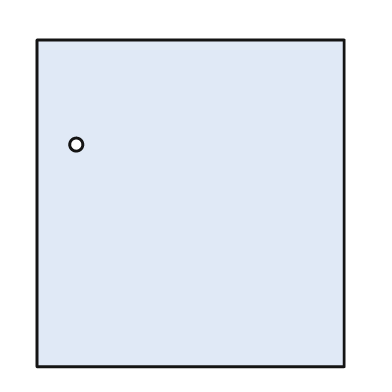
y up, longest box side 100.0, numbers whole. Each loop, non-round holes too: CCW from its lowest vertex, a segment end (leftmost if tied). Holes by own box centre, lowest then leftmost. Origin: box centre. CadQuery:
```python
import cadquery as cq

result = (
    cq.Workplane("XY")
    .moveTo(-47.0, -50.0)
    .lineTo(47.0, -50.0)
    .lineTo(47.0, 50.0)
    .lineTo(-47.0, 50.0)
    .close()
    .moveTo(-35.0, 18.0)
    .circle(2.0)
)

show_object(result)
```